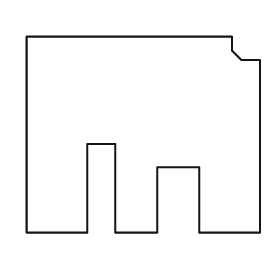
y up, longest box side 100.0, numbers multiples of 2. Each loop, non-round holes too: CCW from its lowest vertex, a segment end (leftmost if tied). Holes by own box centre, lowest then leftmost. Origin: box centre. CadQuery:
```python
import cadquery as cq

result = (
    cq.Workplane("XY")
    .moveTo(-50.0, -42.0)
    .lineTo(-24.0, -42.0)
    .lineTo(-24.0, -4.0)
    .lineTo(-12.0, -4.0)
    .lineTo(-12.0, -42.0)
    .lineTo(6.0, -42.0)
    .lineTo(6.0, -14.0)
    .lineTo(24.0, -14.0)
    .lineTo(24.0, -42.0)
    .lineTo(50.0, -42.0)
    .lineTo(50.0, 32.0)
    .lineTo(42.0, 32.0)
    .lineTo(38.0, 36.0)
    .lineTo(38.0, 42.0)
    .lineTo(-50.0, 42.0)
    .close()
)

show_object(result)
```